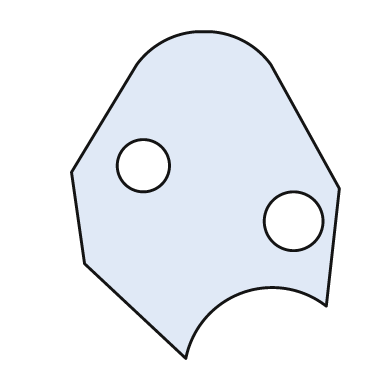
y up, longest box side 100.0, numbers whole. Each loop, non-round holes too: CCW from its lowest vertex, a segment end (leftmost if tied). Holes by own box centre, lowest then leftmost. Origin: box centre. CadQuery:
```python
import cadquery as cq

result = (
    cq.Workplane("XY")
    .moveTo(-6.0, -50.0)
    .threePointArc((11.0, -30.0), (37.0, -34.0))
    .lineTo(41.0, 2.0)
    .lineTo(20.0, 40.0)
    .threePointArc((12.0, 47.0), (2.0, 50.0))
    .lineTo(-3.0, 50.0)
    .threePointArc((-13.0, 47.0), (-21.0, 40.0))
    .lineTo(-41.0, 7.0)
    .lineTo(-37.0, -21.0)
    .close()
    .moveTo(27.0, -8.0)
    .circle(9.0)
    .moveTo(-19.0, 9.0)
    .circle(8.0)
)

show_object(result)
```